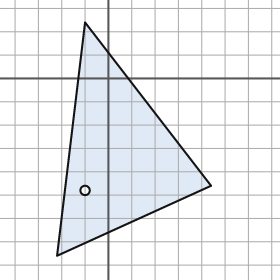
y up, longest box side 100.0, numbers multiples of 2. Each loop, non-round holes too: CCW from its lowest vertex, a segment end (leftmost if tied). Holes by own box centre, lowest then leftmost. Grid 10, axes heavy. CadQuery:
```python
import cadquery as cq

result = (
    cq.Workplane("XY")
    .moveTo(-22.0, -76.0)
    .lineTo(44.0, -46.0)
    .lineTo(-10.0, 24.0)
    .close()
    .moveTo(-10.0, -48.0)
    .circle(2.0)
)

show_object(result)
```